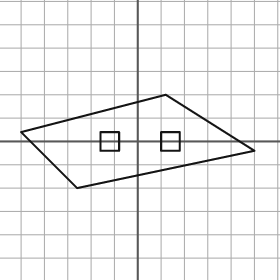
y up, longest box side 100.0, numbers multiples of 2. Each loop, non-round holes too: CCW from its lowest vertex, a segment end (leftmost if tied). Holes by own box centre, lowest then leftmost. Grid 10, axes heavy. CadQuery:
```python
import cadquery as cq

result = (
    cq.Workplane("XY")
    .moveTo(-26.0, -20.0)
    .lineTo(50.0, -4.0)
    .lineTo(12.0, 20.0)
    .lineTo(-50.0, 4.0)
    .close()
    .moveTo(-16.0, -4.0)
    .lineTo(-8.0, -4.0)
    .lineTo(-8.0, 4.0)
    .lineTo(-16.0, 4.0)
    .close()
    .moveTo(10.0, -4.0)
    .lineTo(18.0, -4.0)
    .lineTo(18.0, 4.0)
    .lineTo(10.0, 4.0)
    .close()
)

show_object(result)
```